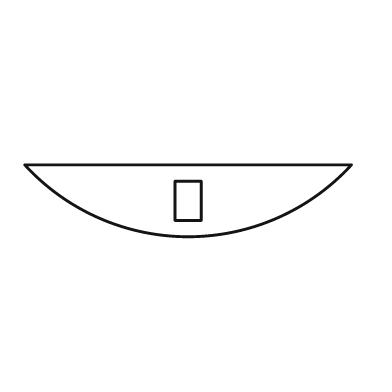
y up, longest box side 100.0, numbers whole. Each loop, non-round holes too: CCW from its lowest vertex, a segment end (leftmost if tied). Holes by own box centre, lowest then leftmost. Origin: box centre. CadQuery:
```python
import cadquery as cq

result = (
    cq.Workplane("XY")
    .moveTo(-50.0, 11.0)
    .threePointArc((0.0, -11.0), (50.0, 11.0))
    .close()
    .moveTo(-4.0, -6.0)
    .lineTo(4.0, -6.0)
    .lineTo(4.0, 6.0)
    .lineTo(-4.0, 6.0)
    .close()
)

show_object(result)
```